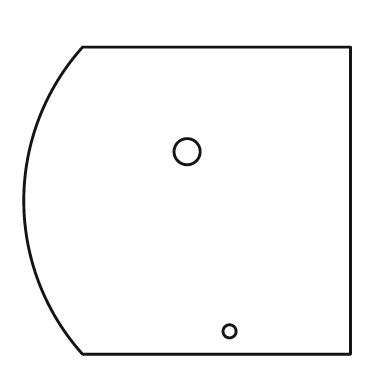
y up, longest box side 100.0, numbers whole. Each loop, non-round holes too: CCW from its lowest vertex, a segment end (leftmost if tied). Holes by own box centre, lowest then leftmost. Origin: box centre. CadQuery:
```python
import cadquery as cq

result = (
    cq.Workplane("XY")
    .moveTo(-32.0, -47.0)
    .lineTo(50.0, -47.0)
    .lineTo(50.0, 47.0)
    .lineTo(-32.0, 47.0)
    .threePointArc((-50.0, 0.0), (-32.0, -47.0))
    .close()
    .moveTo(13.0, -40.0)
    .circle(2.0)
    .moveTo(0.0, 15.0)
    .circle(4.0)
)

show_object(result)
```